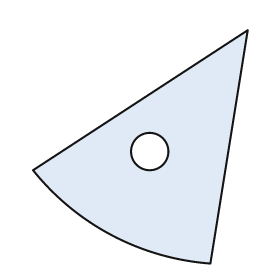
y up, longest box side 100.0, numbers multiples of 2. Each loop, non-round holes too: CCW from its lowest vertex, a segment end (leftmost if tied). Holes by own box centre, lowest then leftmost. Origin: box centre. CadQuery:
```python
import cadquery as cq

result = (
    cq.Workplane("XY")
    .moveTo(30.0, -50.0)
    .lineTo(46.0, 50.0)
    .lineTo(-46.0, -10.0)
    .threePointArc((-12.0, -38.0), (30.0, -50.0))
    .close()
    .moveTo(4.0, -2.0)
    .circle(8.0)
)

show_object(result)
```